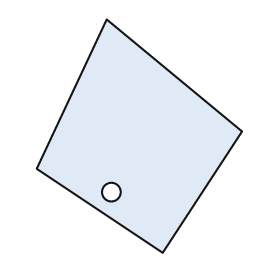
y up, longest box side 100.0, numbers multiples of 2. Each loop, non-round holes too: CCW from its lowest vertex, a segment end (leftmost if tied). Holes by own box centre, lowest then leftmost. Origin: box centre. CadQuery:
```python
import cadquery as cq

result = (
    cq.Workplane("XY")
    .moveTo(10.0, -50.0)
    .lineTo(44.0, 2.0)
    .lineTo(-14.0, 50.0)
    .lineTo(-44.0, -14.0)
    .close()
    .moveTo(-12.0, -24.0)
    .circle(4.0)
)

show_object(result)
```